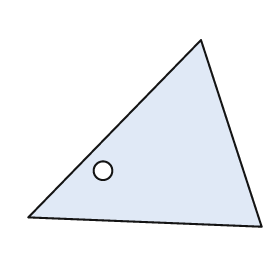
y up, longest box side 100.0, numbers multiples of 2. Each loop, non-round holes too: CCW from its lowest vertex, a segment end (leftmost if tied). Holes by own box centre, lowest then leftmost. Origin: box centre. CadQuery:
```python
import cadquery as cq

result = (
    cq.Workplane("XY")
    .moveTo(50.0, -40.0)
    .lineTo(24.0, 40.0)
    .lineTo(-50.0, -36.0)
    .close()
    .moveTo(-18.0, -16.0)
    .circle(4.0)
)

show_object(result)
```